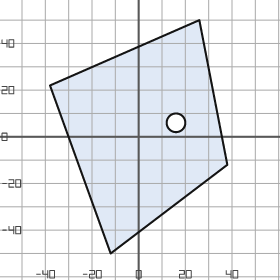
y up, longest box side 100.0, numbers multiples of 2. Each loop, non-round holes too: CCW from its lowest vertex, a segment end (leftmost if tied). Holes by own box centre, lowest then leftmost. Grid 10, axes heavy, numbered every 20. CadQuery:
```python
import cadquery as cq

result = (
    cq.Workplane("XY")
    .moveTo(-12.0, -50.0)
    .lineTo(38.0, -12.0)
    .lineTo(26.0, 50.0)
    .lineTo(-38.0, 22.0)
    .close()
    .moveTo(16.0, 6.0)
    .circle(4.0)
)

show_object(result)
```